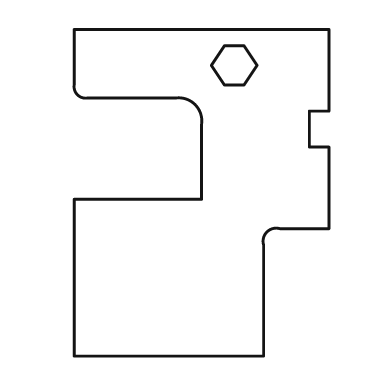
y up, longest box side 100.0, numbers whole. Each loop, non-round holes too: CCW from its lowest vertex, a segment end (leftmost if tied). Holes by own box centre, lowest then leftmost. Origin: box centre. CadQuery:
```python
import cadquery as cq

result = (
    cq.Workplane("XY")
    .moveTo(-39.0, -50.0)
    .lineTo(19.0, -50.0)
    .lineTo(19.0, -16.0)
    .threePointArc((20.0, -12.0), (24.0, -11.0))
    .lineTo(39.0, -11.0)
    .lineTo(39.0, 14.0)
    .lineTo(33.0, 14.0)
    .lineTo(33.0, 25.0)
    .lineTo(39.0, 25.0)
    .lineTo(39.0, 50.0)
    .lineTo(-39.0, 50.0)
    .lineTo(-39.0, 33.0)
    .threePointArc((-38.0, 30.0), (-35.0, 29.0))
    .lineTo(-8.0, 29.0)
    .threePointArc((-2.0, 27.0), (0.0, 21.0))
    .lineTo(0.0, -2.0)
    .lineTo(-39.0, -2.0)
    .close()
    .moveTo(7.0, 33.0)
    .lineTo(13.0, 33.0)
    .lineTo(17.0, 39.0)
    .lineTo(13.0, 45.0)
    .lineTo(7.0, 45.0)
    .lineTo(3.0, 39.0)
    .close()
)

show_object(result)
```